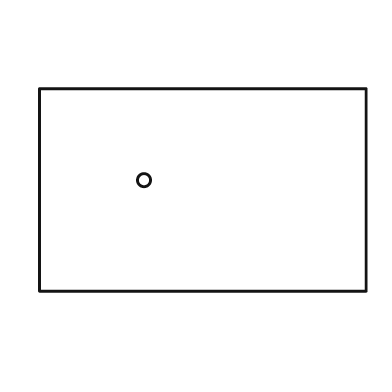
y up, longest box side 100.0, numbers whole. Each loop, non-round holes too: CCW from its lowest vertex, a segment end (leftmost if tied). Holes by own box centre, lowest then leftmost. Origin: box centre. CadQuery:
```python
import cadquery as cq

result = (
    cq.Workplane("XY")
    .moveTo(-50.0, -31.0)
    .lineTo(50.0, -31.0)
    .lineTo(50.0, 31.0)
    .lineTo(-50.0, 31.0)
    .close()
    .moveTo(-18.0, 3.0)
    .circle(2.0)
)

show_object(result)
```